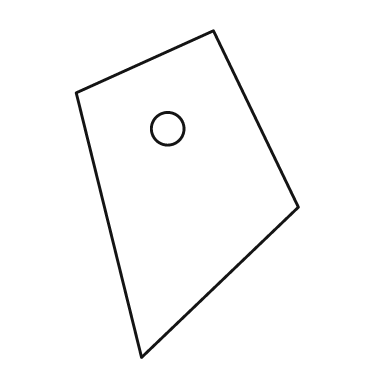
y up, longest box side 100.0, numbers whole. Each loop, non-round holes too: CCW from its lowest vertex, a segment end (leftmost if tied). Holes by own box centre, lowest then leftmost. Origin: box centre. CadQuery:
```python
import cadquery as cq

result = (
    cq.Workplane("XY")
    .moveTo(-14.0, -50.0)
    .lineTo(34.0, -4.0)
    .lineTo(8.0, 50.0)
    .lineTo(-34.0, 31.0)
    .close()
    .moveTo(-6.0, 20.0)
    .circle(5.0)
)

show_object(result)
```